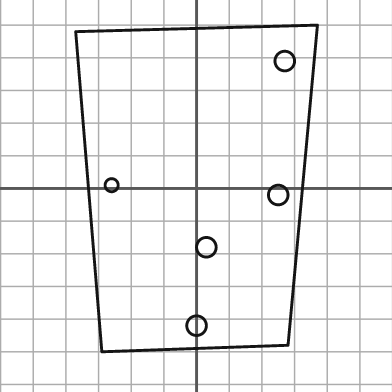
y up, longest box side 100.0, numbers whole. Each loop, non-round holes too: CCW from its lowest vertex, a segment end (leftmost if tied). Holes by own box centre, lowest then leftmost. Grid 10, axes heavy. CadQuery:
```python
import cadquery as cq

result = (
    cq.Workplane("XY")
    .moveTo(-29.0, -50.0)
    .lineTo(28.0, -48.0)
    .lineTo(37.0, 50.0)
    .lineTo(-37.0, 48.0)
    .close()
    .moveTo(0.0, -42.0)
    .circle(3.0)
    .moveTo(3.0, -18.0)
    .circle(3.0)
    .moveTo(25.0, -2.0)
    .circle(3.0)
    .moveTo(-26.0, 1.0)
    .circle(2.0)
    .moveTo(27.0, 39.0)
    .circle(3.0)
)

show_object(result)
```